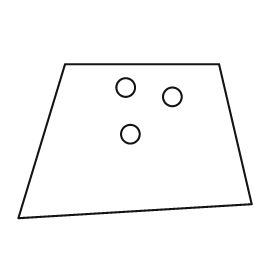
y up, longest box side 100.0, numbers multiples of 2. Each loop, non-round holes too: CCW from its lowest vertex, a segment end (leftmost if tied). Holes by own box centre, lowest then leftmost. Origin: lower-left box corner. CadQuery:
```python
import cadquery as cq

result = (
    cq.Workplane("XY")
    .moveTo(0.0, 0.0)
    .lineTo(100.0, 6.0)
    .lineTo(86.0, 66.0)
    .lineTo(20.0, 66.0)
    .close()
    .moveTo(48.0, 36.0)
    .circle(4.0)
    .moveTo(66.0, 52.0)
    .circle(4.0)
    .moveTo(46.0, 56.0)
    .circle(4.0)
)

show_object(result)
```